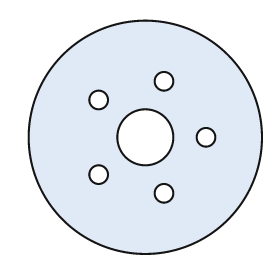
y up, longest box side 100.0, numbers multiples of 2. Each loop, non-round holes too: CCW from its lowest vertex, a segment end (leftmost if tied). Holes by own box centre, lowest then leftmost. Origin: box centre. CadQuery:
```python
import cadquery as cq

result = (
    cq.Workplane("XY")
    .moveTo(0.0, 0.0)
    .circle(50.0)
    .moveTo(8.0, -24.0)
    .circle(4.0)
    .moveTo(-20.0, -16.0)
    .circle(4.0)
    .moveTo(0.0, 0.0)
    .circle(12.0)
    .moveTo(26.0, 0.0)
    .circle(4.0)
    .moveTo(-20.0, 16.0)
    .circle(4.0)
    .moveTo(8.0, 24.0)
    .circle(4.0)
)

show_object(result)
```